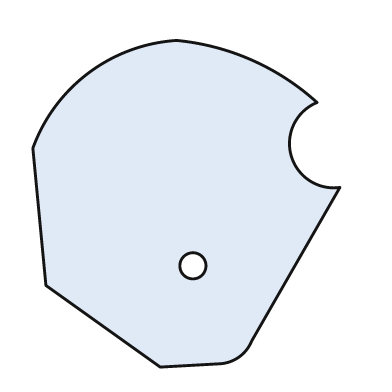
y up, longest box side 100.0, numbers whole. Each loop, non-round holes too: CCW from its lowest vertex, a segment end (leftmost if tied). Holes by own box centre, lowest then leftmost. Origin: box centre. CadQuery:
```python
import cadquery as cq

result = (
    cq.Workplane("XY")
    .moveTo(-8.0, -50.0)
    .lineTo(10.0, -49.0)
    .threePointArc((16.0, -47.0), (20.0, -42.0))
    .lineTo(47.0, 5.0)
    .threePointArc((32.0, 15.0), (40.0, 31.0))
    .threePointArc((20.0, 44.0), (-3.0, 50.0))
    .threePointArc((-30.0, 40.0), (-47.0, 17.0))
    .lineTo(-43.0, -25.0)
    .close()
    .moveTo(2.0, -19.0)
    .circle(4.0)
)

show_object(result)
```